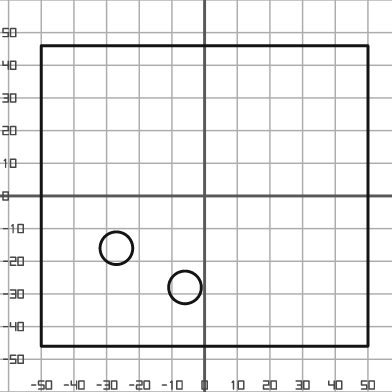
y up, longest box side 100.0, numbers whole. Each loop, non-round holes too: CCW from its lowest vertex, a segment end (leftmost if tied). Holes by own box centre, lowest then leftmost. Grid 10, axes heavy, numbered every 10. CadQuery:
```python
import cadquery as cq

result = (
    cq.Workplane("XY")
    .moveTo(-50.0, -46.0)
    .lineTo(50.0, -46.0)
    .lineTo(50.0, 46.0)
    .lineTo(-50.0, 46.0)
    .close()
    .moveTo(-6.0, -28.0)
    .circle(5.0)
    .moveTo(-27.0, -16.0)
    .circle(5.0)
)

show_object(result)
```